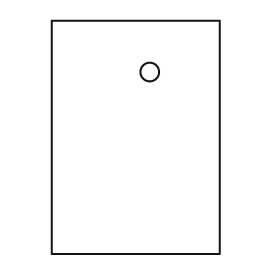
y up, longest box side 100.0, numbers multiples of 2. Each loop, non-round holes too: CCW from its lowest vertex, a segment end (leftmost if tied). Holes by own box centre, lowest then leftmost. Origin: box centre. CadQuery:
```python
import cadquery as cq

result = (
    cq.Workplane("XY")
    .moveTo(-36.0, -50.0)
    .lineTo(36.0, -50.0)
    .lineTo(36.0, 50.0)
    .lineTo(-36.0, 50.0)
    .close()
    .moveTo(6.0, 28.0)
    .circle(4.0)
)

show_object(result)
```